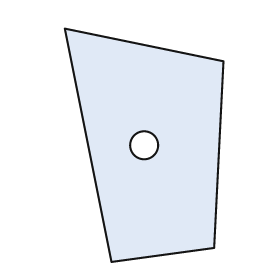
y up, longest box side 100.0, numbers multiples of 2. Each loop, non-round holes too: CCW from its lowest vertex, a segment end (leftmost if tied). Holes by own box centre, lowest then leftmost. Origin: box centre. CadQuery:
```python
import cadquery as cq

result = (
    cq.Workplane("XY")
    .moveTo(-14.0, -50.0)
    .lineTo(30.0, -44.0)
    .lineTo(34.0, 36.0)
    .lineTo(-34.0, 50.0)
    .close()
    .moveTo(0.0, 0.0)
    .circle(6.0)
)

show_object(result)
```